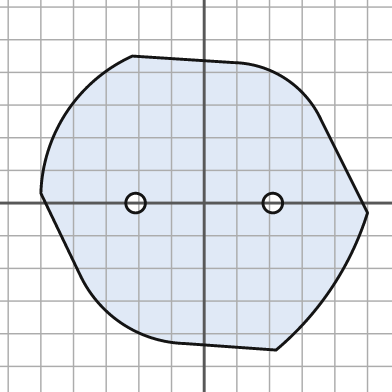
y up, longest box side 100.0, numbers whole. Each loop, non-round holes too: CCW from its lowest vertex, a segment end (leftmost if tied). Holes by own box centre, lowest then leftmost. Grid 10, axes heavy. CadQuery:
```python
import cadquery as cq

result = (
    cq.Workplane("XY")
    .moveTo(22.0, -45.0)
    .threePointArc((39.0, -26.0), (50.0, -3.0))
    .lineTo(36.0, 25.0)
    .threePointArc((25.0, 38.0), (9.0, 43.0))
    .lineTo(-22.0, 45.0)
    .threePointArc((-42.0, 28.0), (-50.0, 3.0))
    .lineTo(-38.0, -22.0)
    .threePointArc((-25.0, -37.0), (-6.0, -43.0))
    .close()
    .moveTo(-21.0, 0.0)
    .circle(3.0)
    .moveTo(21.0, 0.0)
    .circle(3.0)
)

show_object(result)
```